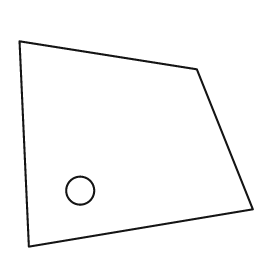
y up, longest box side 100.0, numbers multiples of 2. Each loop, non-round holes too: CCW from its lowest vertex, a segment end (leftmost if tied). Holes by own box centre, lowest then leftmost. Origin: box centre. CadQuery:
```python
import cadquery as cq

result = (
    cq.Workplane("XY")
    .moveTo(-46.0, -44.0)
    .lineTo(50.0, -28.0)
    .lineTo(26.0, 32.0)
    .lineTo(-50.0, 44.0)
    .close()
    .moveTo(-24.0, -20.0)
    .circle(6.0)
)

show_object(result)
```